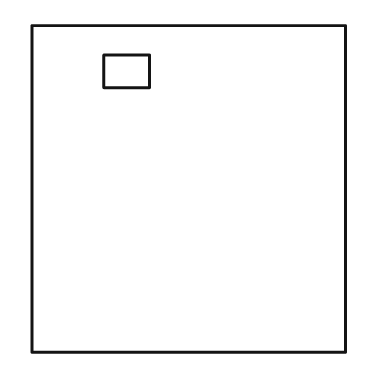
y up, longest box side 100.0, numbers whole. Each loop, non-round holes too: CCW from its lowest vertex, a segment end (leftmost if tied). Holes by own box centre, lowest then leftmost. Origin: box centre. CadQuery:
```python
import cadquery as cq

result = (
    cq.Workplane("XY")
    .moveTo(-48.0, -50.0)
    .lineTo(48.0, -50.0)
    .lineTo(48.0, 50.0)
    .lineTo(-48.0, 50.0)
    .close()
    .moveTo(-26.0, 31.0)
    .lineTo(-12.0, 31.0)
    .lineTo(-12.0, 41.0)
    .lineTo(-26.0, 41.0)
    .close()
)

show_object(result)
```